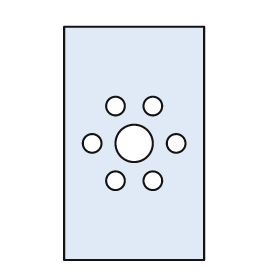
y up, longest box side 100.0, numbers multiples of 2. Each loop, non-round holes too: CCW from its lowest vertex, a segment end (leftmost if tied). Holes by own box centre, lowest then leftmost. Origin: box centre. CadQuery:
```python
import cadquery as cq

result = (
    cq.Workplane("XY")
    .moveTo(-30.0, -50.0)
    .lineTo(30.0, -50.0)
    .lineTo(30.0, 50.0)
    .lineTo(-30.0, 50.0)
    .close()
    .moveTo(-8.0, -16.0)
    .circle(4.0)
    .moveTo(8.0, -16.0)
    .circle(4.0)
    .moveTo(-18.0, 0.0)
    .circle(4.0)
    .moveTo(0.0, 0.0)
    .circle(8.0)
    .moveTo(18.0, 0.0)
    .circle(4.0)
    .moveTo(-8.0, 16.0)
    .circle(4.0)
    .moveTo(8.0, 16.0)
    .circle(4.0)
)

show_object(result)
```